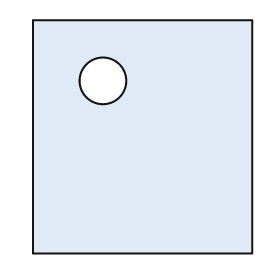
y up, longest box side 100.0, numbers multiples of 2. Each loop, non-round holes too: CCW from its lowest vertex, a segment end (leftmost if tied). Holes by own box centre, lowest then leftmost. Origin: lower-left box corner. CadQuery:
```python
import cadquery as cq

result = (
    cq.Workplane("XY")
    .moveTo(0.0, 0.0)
    .lineTo(94.0, 0.0)
    .lineTo(94.0, 100.0)
    .lineTo(0.0, 100.0)
    .close()
    .moveTo(30.0, 74.0)
    .circle(10.0)
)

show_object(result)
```